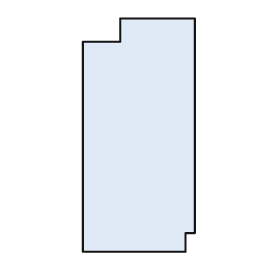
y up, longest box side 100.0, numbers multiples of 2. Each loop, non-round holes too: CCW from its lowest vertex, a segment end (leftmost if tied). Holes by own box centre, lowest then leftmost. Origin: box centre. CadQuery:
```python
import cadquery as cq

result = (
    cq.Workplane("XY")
    .moveTo(-24.0, -50.0)
    .lineTo(20.0, -50.0)
    .lineTo(20.0, -42.0)
    .lineTo(24.0, -42.0)
    .lineTo(24.0, 50.0)
    .lineTo(-8.0, 50.0)
    .lineTo(-8.0, 40.0)
    .lineTo(-24.0, 40.0)
    .close()
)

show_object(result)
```